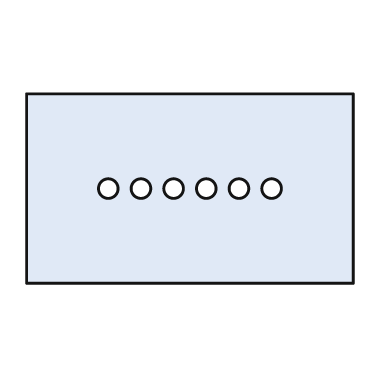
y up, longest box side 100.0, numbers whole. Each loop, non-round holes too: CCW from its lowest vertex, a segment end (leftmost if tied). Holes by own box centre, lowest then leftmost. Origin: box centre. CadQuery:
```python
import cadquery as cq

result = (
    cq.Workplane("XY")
    .moveTo(-50.0, -29.0)
    .lineTo(50.0, -29.0)
    .lineTo(50.0, 29.0)
    .lineTo(-50.0, 29.0)
    .close()
    .moveTo(-25.0, 0.0)
    .circle(3.0)
    .moveTo(-15.0, 0.0)
    .circle(3.0)
    .moveTo(-5.0, 0.0)
    .circle(3.0)
    .moveTo(5.0, 0.0)
    .circle(3.0)
    .moveTo(15.0, 0.0)
    .circle(3.0)
    .moveTo(25.0, 0.0)
    .circle(3.0)
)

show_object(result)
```